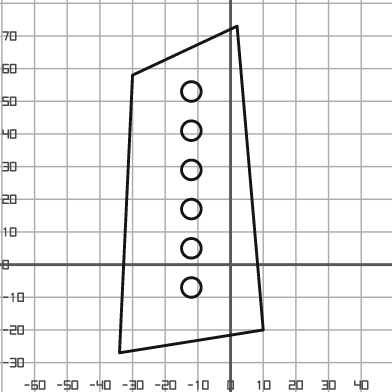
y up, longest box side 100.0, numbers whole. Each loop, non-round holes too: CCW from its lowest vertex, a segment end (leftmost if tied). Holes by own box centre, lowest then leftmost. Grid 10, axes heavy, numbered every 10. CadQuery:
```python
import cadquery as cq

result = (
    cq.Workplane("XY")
    .moveTo(-34.0, -27.0)
    .lineTo(10.0, -20.0)
    .lineTo(2.0, 73.0)
    .lineTo(-30.0, 58.0)
    .close()
    .moveTo(-12.0, -7.0)
    .circle(3.0)
    .moveTo(-12.0, 5.0)
    .circle(3.0)
    .moveTo(-12.0, 17.0)
    .circle(3.0)
    .moveTo(-12.0, 29.0)
    .circle(3.0)
    .moveTo(-12.0, 41.0)
    .circle(3.0)
    .moveTo(-12.0, 53.0)
    .circle(3.0)
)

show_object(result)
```